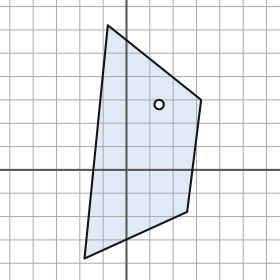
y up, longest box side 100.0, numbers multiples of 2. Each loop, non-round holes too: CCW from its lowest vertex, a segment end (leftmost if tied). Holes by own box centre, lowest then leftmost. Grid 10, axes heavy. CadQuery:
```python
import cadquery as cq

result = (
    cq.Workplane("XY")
    .moveTo(-18.0, -38.0)
    .lineTo(26.0, -18.0)
    .lineTo(32.0, 30.0)
    .lineTo(-8.0, 62.0)
    .close()
    .moveTo(14.0, 28.0)
    .circle(2.0)
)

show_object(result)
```